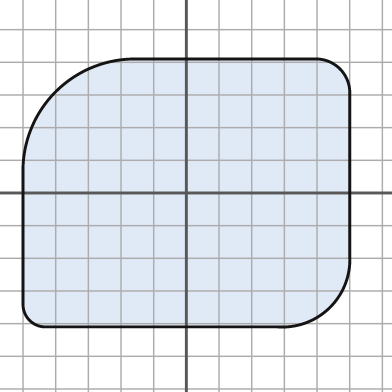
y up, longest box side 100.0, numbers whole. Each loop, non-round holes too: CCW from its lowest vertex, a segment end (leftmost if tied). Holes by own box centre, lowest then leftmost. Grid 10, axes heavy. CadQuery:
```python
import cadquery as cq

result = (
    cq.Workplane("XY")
    .moveTo(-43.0, -41.0)
    .lineTo(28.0, -41.0)
    .threePointArc((44.0, -35.0), (50.0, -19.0))
    .lineTo(50.0, 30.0)
    .threePointArc((47.0, 38.0), (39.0, 41.0))
    .lineTo(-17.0, 41.0)
    .threePointArc((-40.0, 31.0), (-50.0, 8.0))
    .lineTo(-50.0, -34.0)
    .threePointArc((-48.0, -39.0), (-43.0, -41.0))
    .close()
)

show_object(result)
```